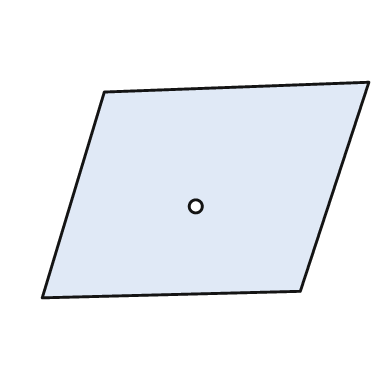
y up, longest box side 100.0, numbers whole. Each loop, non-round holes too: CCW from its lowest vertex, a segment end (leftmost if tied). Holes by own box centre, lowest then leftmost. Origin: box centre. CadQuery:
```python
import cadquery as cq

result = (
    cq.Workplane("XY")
    .moveTo(-50.0, -33.0)
    .lineTo(29.0, -31.0)
    .lineTo(50.0, 33.0)
    .lineTo(-31.0, 30.0)
    .close()
    .moveTo(-3.0, -5.0)
    .circle(2.0)
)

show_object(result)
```